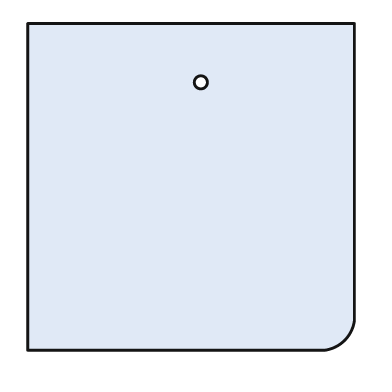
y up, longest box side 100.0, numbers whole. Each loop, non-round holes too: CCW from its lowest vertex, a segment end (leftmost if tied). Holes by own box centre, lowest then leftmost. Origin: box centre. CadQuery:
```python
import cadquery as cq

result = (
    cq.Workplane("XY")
    .moveTo(-50.0, -50.0)
    .lineTo(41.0, -50.0)
    .threePointArc((47.0, -47.0), (50.0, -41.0))
    .lineTo(50.0, 50.0)
    .lineTo(-50.0, 50.0)
    .close()
    .moveTo(3.0, 32.0)
    .circle(2.0)
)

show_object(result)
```